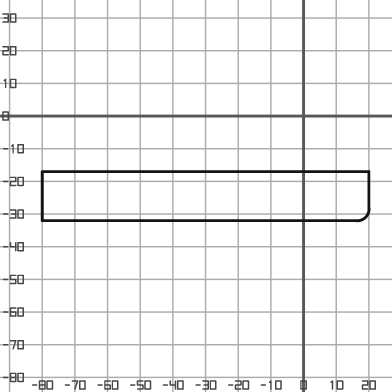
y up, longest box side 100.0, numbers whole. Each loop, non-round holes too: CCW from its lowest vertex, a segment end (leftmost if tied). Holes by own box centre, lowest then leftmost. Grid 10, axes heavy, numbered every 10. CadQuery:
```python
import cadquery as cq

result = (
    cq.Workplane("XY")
    .moveTo(-80.0, -32.0)
    .lineTo(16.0, -32.0)
    .threePointArc((19.0, -31.0), (20.0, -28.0))
    .lineTo(20.0, -17.0)
    .lineTo(-80.0, -17.0)
    .close()
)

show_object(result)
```